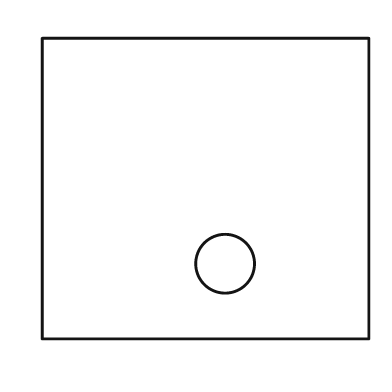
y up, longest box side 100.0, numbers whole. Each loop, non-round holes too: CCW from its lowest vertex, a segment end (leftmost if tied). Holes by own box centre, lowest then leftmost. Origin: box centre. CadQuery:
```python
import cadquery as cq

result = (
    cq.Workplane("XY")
    .moveTo(-50.0, -46.0)
    .lineTo(50.0, -46.0)
    .lineTo(50.0, 46.0)
    .lineTo(-50.0, 46.0)
    .close()
    .moveTo(6.0, -23.0)
    .circle(9.0)
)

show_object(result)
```